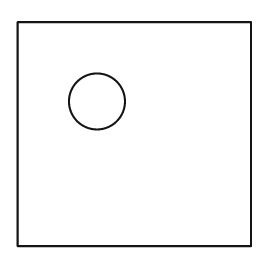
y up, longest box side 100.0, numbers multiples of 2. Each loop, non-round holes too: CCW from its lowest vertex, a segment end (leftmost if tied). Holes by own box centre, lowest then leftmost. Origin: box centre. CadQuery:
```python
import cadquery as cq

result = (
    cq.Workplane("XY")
    .moveTo(-50.0, -48.0)
    .lineTo(50.0, -48.0)
    .lineTo(50.0, 48.0)
    .lineTo(-50.0, 48.0)
    .close()
    .moveTo(-16.0, 14.0)
    .circle(12.0)
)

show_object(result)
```